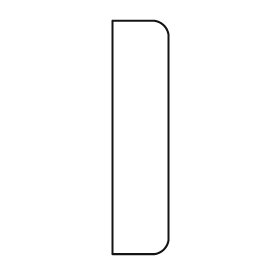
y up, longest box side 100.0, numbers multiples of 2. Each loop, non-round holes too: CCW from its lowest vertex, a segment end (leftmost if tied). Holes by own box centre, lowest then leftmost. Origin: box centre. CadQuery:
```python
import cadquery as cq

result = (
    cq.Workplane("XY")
    .moveTo(-12.0, -50.0)
    .lineTo(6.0, -50.0)
    .threePointArc((10.0, -48.0), (12.0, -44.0))
    .lineTo(12.0, 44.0)
    .threePointArc((10.0, 48.0), (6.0, 50.0))
    .lineTo(-12.0, 50.0)
    .close()
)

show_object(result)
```